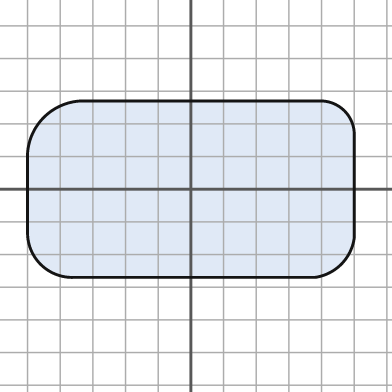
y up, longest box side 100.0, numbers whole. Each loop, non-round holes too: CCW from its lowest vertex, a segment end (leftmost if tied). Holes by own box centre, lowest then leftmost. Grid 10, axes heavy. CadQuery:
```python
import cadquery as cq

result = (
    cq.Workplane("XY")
    .moveTo(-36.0, -27.0)
    .lineTo(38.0, -27.0)
    .threePointArc((46.0, -23.0), (50.0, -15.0))
    .lineTo(50.0, 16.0)
    .threePointArc((47.0, 24.0), (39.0, 27.0))
    .lineTo(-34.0, 27.0)
    .threePointArc((-45.0, 22.0), (-50.0, 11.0))
    .lineTo(-50.0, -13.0)
    .threePointArc((-46.0, -23.0), (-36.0, -27.0))
    .close()
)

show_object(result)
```